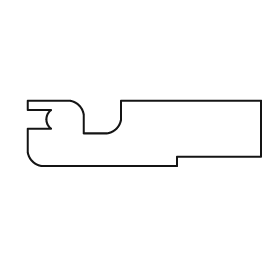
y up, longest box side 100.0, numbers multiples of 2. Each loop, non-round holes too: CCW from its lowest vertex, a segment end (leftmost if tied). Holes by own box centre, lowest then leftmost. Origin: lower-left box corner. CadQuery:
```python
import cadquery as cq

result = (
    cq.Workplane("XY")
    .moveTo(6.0, 0.0)
    .lineTo(64.0, 0.0)
    .lineTo(64.0, 4.0)
    .lineTo(100.0, 4.0)
    .lineTo(100.0, 28.0)
    .lineTo(40.0, 28.0)
    .lineTo(40.0, 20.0)
    .threePointArc((38.0, 16.0), (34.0, 14.0))
    .lineTo(24.0, 14.0)
    .lineTo(24.0, 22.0)
    .threePointArc((22.0, 26.0), (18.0, 28.0))
    .lineTo(0.0, 28.0)
    .lineTo(0.0, 24.0)
    .lineTo(10.0, 24.0)
    .threePointArc((8.0, 20.0), (10.0, 16.0))
    .lineTo(0.0, 16.0)
    .lineTo(0.0, 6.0)
    .threePointArc((2.0, 2.0), (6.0, 0.0))
    .close()
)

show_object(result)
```